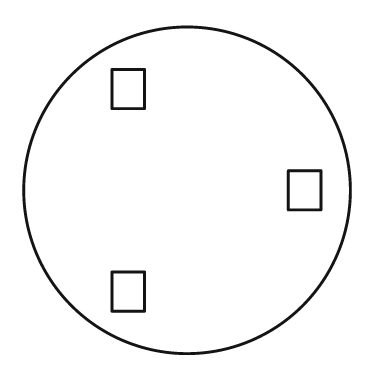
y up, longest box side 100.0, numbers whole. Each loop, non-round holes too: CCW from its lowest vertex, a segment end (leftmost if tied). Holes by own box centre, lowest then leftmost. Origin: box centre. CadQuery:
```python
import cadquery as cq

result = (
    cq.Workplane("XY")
    .moveTo(0.0, 0.0)
    .circle(50.0)
    .moveTo(-23.0, -37.0)
    .lineTo(-13.0, -37.0)
    .lineTo(-13.0, -25.0)
    .lineTo(-23.0, -25.0)
    .close()
    .moveTo(31.0, -6.0)
    .lineTo(41.0, -6.0)
    .lineTo(41.0, 6.0)
    .lineTo(31.0, 6.0)
    .close()
    .moveTo(-23.0, 25.0)
    .lineTo(-13.0, 25.0)
    .lineTo(-13.0, 37.0)
    .lineTo(-23.0, 37.0)
    .close()
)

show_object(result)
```